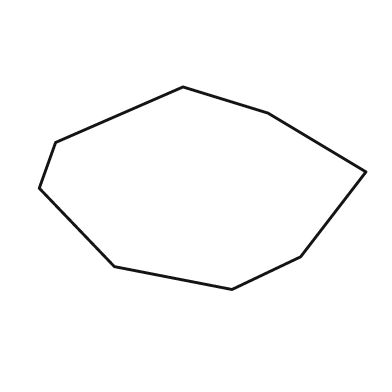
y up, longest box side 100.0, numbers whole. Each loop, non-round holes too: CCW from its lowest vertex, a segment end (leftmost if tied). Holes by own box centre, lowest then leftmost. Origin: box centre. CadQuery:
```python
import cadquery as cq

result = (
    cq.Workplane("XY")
    .moveTo(9.0, -31.0)
    .lineTo(30.0, -21.0)
    .lineTo(50.0, 5.0)
    .lineTo(20.0, 23.0)
    .lineTo(-6.0, 31.0)
    .lineTo(-45.0, 14.0)
    .lineTo(-50.0, 0.0)
    .lineTo(-27.0, -24.0)
    .close()
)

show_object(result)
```